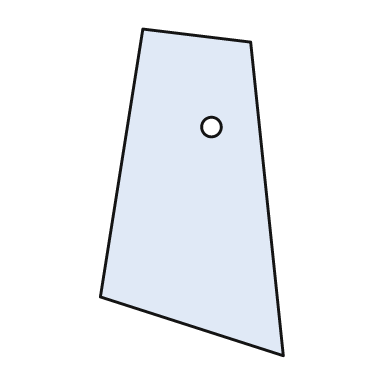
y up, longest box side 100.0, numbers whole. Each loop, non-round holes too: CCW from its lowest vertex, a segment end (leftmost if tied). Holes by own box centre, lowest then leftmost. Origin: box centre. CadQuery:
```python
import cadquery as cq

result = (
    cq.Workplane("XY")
    .moveTo(28.0, -50.0)
    .lineTo(18.0, 46.0)
    .lineTo(-15.0, 50.0)
    .lineTo(-28.0, -32.0)
    .close()
    .moveTo(6.0, 20.0)
    .circle(3.0)
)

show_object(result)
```